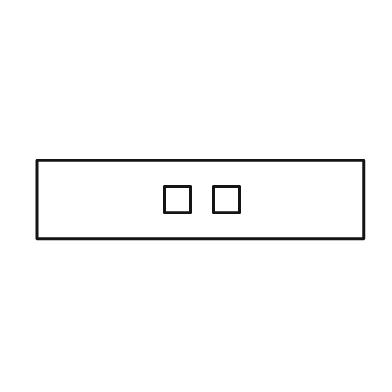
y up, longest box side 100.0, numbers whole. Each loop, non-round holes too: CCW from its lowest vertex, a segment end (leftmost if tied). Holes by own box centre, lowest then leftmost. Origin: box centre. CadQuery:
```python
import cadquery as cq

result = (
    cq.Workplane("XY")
    .moveTo(-50.0, -12.0)
    .lineTo(50.0, -12.0)
    .lineTo(50.0, 12.0)
    .lineTo(-50.0, 12.0)
    .close()
    .moveTo(-11.0, -4.0)
    .lineTo(-3.0, -4.0)
    .lineTo(-3.0, 4.0)
    .lineTo(-11.0, 4.0)
    .close()
    .moveTo(4.0, -4.0)
    .lineTo(12.0, -4.0)
    .lineTo(12.0, 4.0)
    .lineTo(4.0, 4.0)
    .close()
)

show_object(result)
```